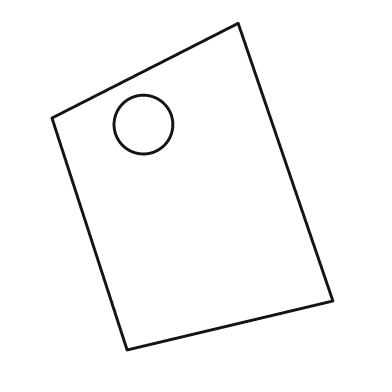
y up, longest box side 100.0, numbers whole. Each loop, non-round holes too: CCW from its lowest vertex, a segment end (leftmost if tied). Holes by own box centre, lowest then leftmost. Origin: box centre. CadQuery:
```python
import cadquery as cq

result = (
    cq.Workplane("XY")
    .moveTo(-20.0, -50.0)
    .lineTo(43.0, -35.0)
    .lineTo(14.0, 50.0)
    .lineTo(-43.0, 21.0)
    .close()
    .moveTo(-15.0, 19.0)
    .circle(9.0)
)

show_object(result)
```